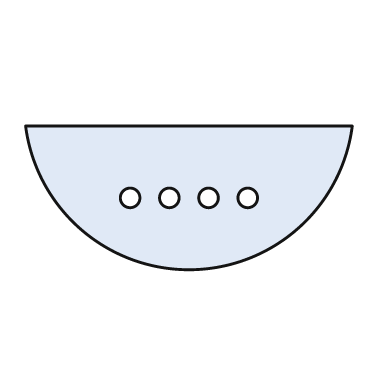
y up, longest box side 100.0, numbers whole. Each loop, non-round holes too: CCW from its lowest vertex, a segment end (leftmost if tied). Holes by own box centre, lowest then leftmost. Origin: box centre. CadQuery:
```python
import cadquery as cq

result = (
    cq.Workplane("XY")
    .moveTo(-50.0, 22.0)
    .threePointArc((0.0, -22.0), (50.0, 22.0))
    .close()
    .moveTo(-18.0, 0.0)
    .circle(3.0)
    .moveTo(-6.0, 0.0)
    .circle(3.0)
    .moveTo(6.0, 0.0)
    .circle(3.0)
    .moveTo(18.0, 0.0)
    .circle(3.0)
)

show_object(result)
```